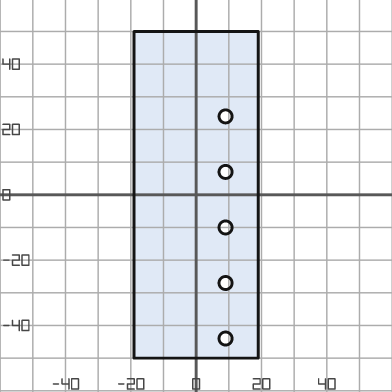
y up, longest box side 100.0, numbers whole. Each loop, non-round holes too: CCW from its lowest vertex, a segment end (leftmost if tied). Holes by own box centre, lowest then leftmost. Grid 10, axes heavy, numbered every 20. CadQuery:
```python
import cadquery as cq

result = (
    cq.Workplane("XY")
    .moveTo(-19.0, -50.0)
    .lineTo(19.0, -50.0)
    .lineTo(19.0, 50.0)
    .lineTo(-19.0, 50.0)
    .close()
    .moveTo(9.0, -44.0)
    .circle(2.0)
    .moveTo(9.0, -27.0)
    .circle(2.0)
    .moveTo(9.0, -10.0)
    .circle(2.0)
    .moveTo(9.0, 7.0)
    .circle(2.0)
    .moveTo(9.0, 24.0)
    .circle(2.0)
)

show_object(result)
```